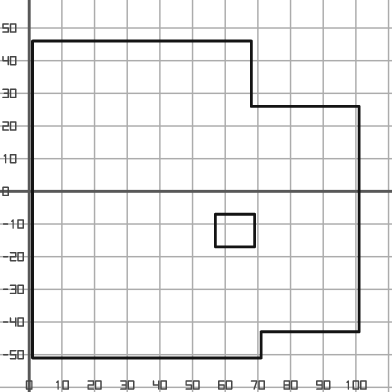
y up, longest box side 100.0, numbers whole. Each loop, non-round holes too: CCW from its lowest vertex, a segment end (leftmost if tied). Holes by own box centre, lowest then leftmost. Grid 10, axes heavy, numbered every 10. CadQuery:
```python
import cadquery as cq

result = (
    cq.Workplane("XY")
    .moveTo(1.0, -51.0)
    .lineTo(71.0, -51.0)
    .lineTo(71.0, -43.0)
    .lineTo(101.0, -43.0)
    .lineTo(101.0, 26.0)
    .lineTo(68.0, 26.0)
    .lineTo(68.0, 46.0)
    .lineTo(1.0, 46.0)
    .close()
    .moveTo(57.0, -17.0)
    .lineTo(69.0, -17.0)
    .lineTo(69.0, -7.0)
    .lineTo(57.0, -7.0)
    .close()
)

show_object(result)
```